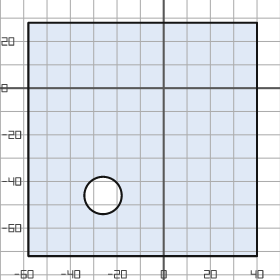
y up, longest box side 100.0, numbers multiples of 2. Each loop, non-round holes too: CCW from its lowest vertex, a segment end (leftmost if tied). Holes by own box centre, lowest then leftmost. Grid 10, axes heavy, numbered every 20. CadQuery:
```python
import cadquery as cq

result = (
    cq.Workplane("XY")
    .moveTo(-58.0, -72.0)
    .lineTo(40.0, -72.0)
    .lineTo(40.0, 28.0)
    .lineTo(-58.0, 28.0)
    .close()
    .moveTo(-26.0, -46.0)
    .circle(8.0)
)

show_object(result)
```